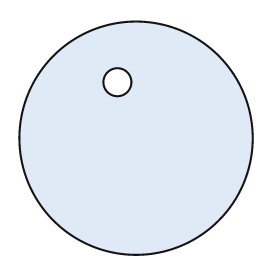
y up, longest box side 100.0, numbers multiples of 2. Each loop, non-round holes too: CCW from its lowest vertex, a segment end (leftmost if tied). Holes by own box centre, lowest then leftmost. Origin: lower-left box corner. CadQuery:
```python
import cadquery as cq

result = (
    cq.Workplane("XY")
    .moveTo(50.0, 50.0)
    .circle(50.0)
    .moveTo(42.0, 74.0)
    .circle(6.0)
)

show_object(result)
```